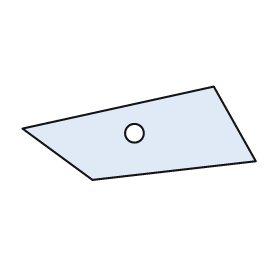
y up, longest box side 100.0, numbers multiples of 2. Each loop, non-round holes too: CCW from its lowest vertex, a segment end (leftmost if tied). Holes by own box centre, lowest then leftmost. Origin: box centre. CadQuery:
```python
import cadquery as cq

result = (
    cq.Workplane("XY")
    .moveTo(-20.0, -20.0)
    .lineTo(50.0, -12.0)
    .lineTo(32.0, 20.0)
    .lineTo(-50.0, 2.0)
    .close()
    .moveTo(-2.0, 0.0)
    .circle(4.0)
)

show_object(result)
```